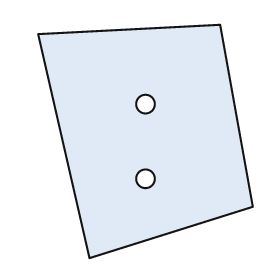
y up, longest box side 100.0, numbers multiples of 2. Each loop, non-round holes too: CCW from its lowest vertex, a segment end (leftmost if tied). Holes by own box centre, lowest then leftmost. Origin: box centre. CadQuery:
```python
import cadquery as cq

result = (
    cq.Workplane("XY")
    .moveTo(-24.0, -50.0)
    .lineTo(46.0, -28.0)
    .lineTo(32.0, 50.0)
    .lineTo(-46.0, 46.0)
    .close()
    .moveTo(0.0, -16.0)
    .circle(4.0)
    .moveTo(0.0, 16.0)
    .circle(4.0)
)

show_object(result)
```